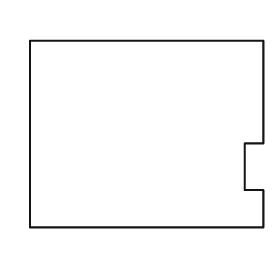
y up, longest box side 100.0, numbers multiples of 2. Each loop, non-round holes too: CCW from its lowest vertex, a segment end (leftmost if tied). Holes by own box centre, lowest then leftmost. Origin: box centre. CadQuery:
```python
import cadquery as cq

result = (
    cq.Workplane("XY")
    .moveTo(-50.0, -40.0)
    .lineTo(50.0, -40.0)
    .lineTo(50.0, -24.0)
    .lineTo(42.0, -24.0)
    .lineTo(42.0, -4.0)
    .lineTo(50.0, -4.0)
    .lineTo(50.0, 40.0)
    .lineTo(-50.0, 40.0)
    .close()
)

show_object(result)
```